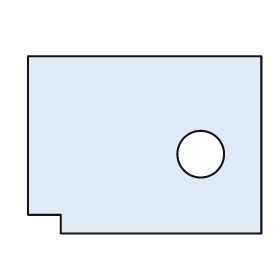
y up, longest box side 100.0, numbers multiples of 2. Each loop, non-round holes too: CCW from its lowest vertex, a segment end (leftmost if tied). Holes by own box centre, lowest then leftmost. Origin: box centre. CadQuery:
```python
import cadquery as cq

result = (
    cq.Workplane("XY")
    .moveTo(-36.0, -38.0)
    .lineTo(50.0, -38.0)
    .lineTo(50.0, 38.0)
    .lineTo(-50.0, 38.0)
    .lineTo(-50.0, -30.0)
    .lineTo(-36.0, -30.0)
    .close()
    .moveTo(24.0, -4.0)
    .circle(10.0)
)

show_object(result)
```